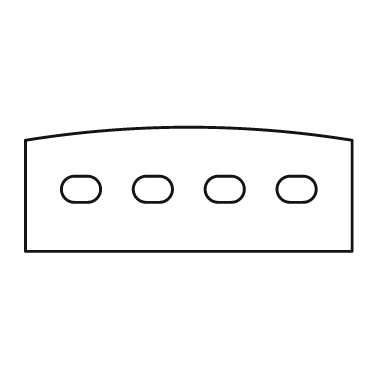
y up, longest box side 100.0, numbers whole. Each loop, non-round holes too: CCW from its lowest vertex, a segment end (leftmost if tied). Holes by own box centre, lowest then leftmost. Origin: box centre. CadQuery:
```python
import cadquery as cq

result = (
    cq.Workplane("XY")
    .moveTo(-50.0, -19.0)
    .lineTo(50.0, -19.0)
    .lineTo(50.0, 15.0)
    .threePointArc((0.0, 19.0), (-50.0, 15.0))
    .close()
    .moveTo(-35.0, -4.0)
    .lineTo(-31.0, -4.0)
    .threePointArc((-27.0, 0.0), (-31.0, 4.0))
    .lineTo(-35.0, 4.0)
    .threePointArc((-39.0, 0.0), (-35.0, -4.0))
    .close()
    .moveTo(-13.0, -4.0)
    .lineTo(-9.0, -4.0)
    .threePointArc((-5.0, 0.0), (-9.0, 4.0))
    .lineTo(-13.0, 4.0)
    .threePointArc((-17.0, 0.0), (-13.0, -4.0))
    .close()
    .moveTo(9.0, -4.0)
    .lineTo(13.0, -4.0)
    .threePointArc((17.0, 0.0), (13.0, 4.0))
    .lineTo(9.0, 4.0)
    .threePointArc((5.0, 0.0), (9.0, -4.0))
    .close()
    .moveTo(31.0, -4.0)
    .lineTo(35.0, -4.0)
    .threePointArc((39.0, 0.0), (35.0, 4.0))
    .lineTo(31.0, 4.0)
    .threePointArc((27.0, 0.0), (31.0, -4.0))
    .close()
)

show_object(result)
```